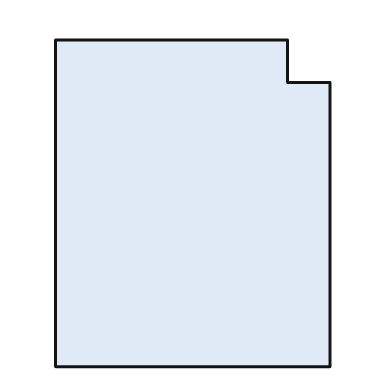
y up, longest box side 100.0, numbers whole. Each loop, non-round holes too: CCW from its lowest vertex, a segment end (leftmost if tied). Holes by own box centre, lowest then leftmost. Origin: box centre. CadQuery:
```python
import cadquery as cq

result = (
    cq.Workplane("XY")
    .moveTo(-42.0, -50.0)
    .lineTo(42.0, -50.0)
    .lineTo(42.0, 37.0)
    .lineTo(29.0, 37.0)
    .lineTo(29.0, 50.0)
    .lineTo(-42.0, 50.0)
    .close()
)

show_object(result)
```